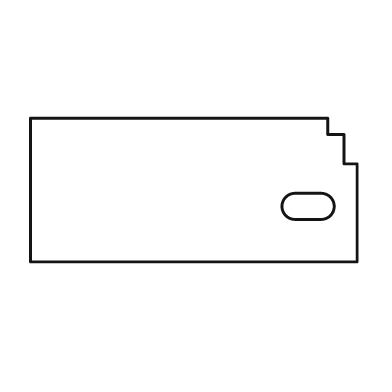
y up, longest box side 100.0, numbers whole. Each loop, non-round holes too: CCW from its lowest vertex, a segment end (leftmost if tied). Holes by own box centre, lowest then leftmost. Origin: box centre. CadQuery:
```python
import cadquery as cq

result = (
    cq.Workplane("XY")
    .moveTo(-50.0, -22.0)
    .lineTo(50.0, -22.0)
    .lineTo(50.0, 8.0)
    .lineTo(46.0, 8.0)
    .lineTo(46.0, 17.0)
    .lineTo(41.0, 17.0)
    .lineTo(41.0, 22.0)
    .lineTo(-50.0, 22.0)
    .close()
    .moveTo(31.0, -9.0)
    .lineTo(39.0, -9.0)
    .threePointArc((43.0, -5.0), (39.0, -1.0))
    .lineTo(31.0, -1.0)
    .threePointArc((27.0, -5.0), (31.0, -9.0))
    .close()
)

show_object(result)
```